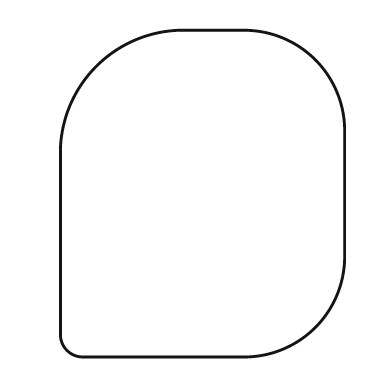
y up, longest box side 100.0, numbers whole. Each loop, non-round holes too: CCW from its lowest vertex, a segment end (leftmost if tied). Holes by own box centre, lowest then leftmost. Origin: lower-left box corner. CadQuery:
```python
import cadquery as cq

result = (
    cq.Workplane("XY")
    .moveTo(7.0, 0.0)
    .lineTo(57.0, 0.0)
    .threePointArc((78.0, 9.0), (87.0, 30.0))
    .lineTo(87.0, 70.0)
    .threePointArc((78.0, 91.0), (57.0, 100.0))
    .lineTo(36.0, 100.0)
    .threePointArc((11.0, 89.0), (0.0, 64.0))
    .lineTo(0.0, 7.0)
    .threePointArc((2.0, 2.0), (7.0, 0.0))
    .close()
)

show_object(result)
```